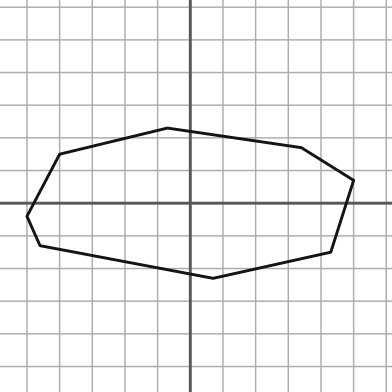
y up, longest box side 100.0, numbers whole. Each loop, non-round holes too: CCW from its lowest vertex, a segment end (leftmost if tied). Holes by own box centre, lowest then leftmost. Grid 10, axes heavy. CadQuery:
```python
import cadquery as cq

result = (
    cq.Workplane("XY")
    .moveTo(7.0, -23.0)
    .lineTo(43.0, -15.0)
    .lineTo(50.0, 7.0)
    .lineTo(34.0, 17.0)
    .lineTo(-7.0, 23.0)
    .lineTo(-40.0, 15.0)
    .lineTo(-50.0, -4.0)
    .lineTo(-46.0, -13.0)
    .close()
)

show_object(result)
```